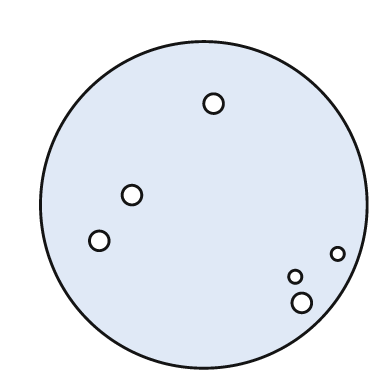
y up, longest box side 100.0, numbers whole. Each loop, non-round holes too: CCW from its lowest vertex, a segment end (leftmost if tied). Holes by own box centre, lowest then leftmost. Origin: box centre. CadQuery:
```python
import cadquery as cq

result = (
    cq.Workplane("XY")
    .moveTo(0.0, 0.0)
    .circle(50.0)
    .moveTo(30.0, -30.0)
    .circle(3.0)
    .moveTo(28.0, -22.0)
    .circle(2.0)
    .moveTo(41.0, -15.0)
    .circle(2.0)
    .moveTo(-32.0, -11.0)
    .circle(3.0)
    .moveTo(-22.0, 3.0)
    .circle(3.0)
    .moveTo(3.0, 31.0)
    .circle(3.0)
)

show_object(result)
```